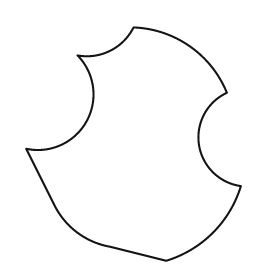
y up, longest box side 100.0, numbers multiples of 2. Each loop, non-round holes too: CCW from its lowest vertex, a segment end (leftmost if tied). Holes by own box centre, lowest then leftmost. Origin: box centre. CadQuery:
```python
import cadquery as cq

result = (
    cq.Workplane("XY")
    .moveTo(14.0, -50.0)
    .threePointArc((34.0, -38.0), (46.0, -18.0))
    .threePointArc((28.0, 0.0), (40.0, 22.0))
    .threePointArc((24.0, 42.0), (0.0, 50.0))
    .threePointArc((-10.0, 40.0), (-24.0, 38.0))
    .threePointArc((-20.0, 10.0), (-46.0, -2.0))
    .lineTo(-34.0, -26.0)
    .threePointArc((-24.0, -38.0), (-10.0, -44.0))
    .close()
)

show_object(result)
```